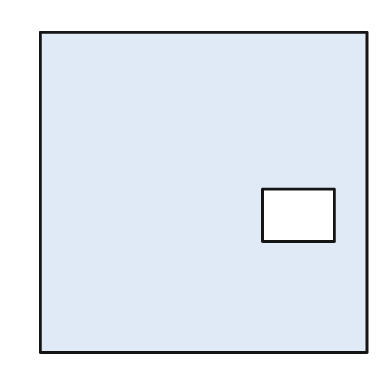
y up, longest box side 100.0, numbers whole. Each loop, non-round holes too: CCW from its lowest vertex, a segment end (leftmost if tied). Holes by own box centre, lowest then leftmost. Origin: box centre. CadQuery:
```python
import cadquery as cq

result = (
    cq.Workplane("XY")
    .moveTo(-50.0, -49.0)
    .lineTo(50.0, -49.0)
    .lineTo(50.0, 49.0)
    .lineTo(-50.0, 49.0)
    .close()
    .moveTo(18.0, -15.0)
    .lineTo(40.0, -15.0)
    .lineTo(40.0, 1.0)
    .lineTo(18.0, 1.0)
    .close()
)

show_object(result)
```